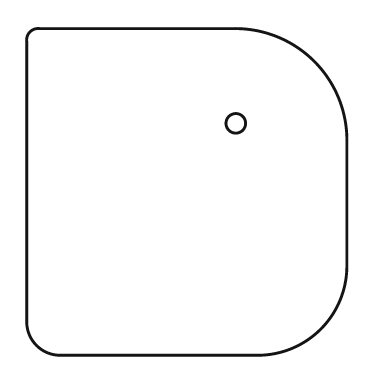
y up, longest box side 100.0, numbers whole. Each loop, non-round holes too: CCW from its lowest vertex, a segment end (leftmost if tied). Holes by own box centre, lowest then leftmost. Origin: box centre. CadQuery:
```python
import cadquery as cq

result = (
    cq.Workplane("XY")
    .moveTo(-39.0, -50.0)
    .lineTo(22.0, -50.0)
    .threePointArc((41.0, -42.0), (49.0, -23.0))
    .lineTo(49.0, 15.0)
    .threePointArc((39.0, 40.0), (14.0, 50.0))
    .lineTo(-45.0, 50.0)
    .threePointArc((-48.0, 49.0), (-49.0, 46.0))
    .lineTo(-49.0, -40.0)
    .threePointArc((-46.0, -47.0), (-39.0, -50.0))
    .close()
    .moveTo(15.0, 21.0)
    .circle(3.0)
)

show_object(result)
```